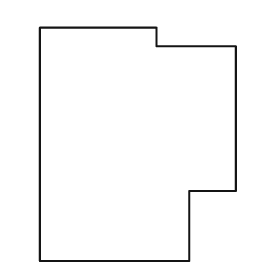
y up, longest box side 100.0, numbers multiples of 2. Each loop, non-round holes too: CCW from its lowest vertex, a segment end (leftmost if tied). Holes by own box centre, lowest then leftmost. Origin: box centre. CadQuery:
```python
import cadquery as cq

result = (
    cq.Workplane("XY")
    .moveTo(-42.0, -50.0)
    .lineTo(22.0, -50.0)
    .lineTo(22.0, -20.0)
    .lineTo(42.0, -20.0)
    .lineTo(42.0, 42.0)
    .lineTo(8.0, 42.0)
    .lineTo(8.0, 50.0)
    .lineTo(-42.0, 50.0)
    .close()
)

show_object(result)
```